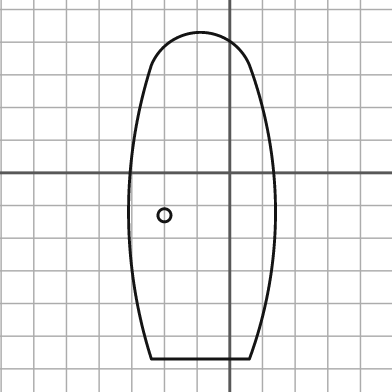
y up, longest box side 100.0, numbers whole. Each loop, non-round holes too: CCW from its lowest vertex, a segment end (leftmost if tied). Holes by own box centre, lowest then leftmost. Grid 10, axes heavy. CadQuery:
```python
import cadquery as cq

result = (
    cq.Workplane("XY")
    .moveTo(-24.0, -57.0)
    .lineTo(6.0, -57.0)
    .threePointArc((14.0, -12.0), (6.0, 33.0))
    .threePointArc((-9.0, 43.0), (-24.0, 33.0))
    .threePointArc((-31.0, -12.0), (-24.0, -57.0))
    .close()
    .moveTo(-20.0, -13.0)
    .circle(2.0)
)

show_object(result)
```